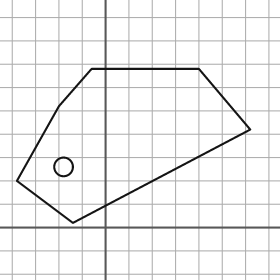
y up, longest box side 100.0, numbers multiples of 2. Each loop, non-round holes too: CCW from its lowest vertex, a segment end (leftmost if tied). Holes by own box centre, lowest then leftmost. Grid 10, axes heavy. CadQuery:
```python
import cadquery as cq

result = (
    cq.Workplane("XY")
    .moveTo(-14.0, 2.0)
    .lineTo(62.0, 42.0)
    .lineTo(40.0, 68.0)
    .lineTo(-6.0, 68.0)
    .lineTo(-20.0, 52.0)
    .lineTo(-38.0, 20.0)
    .close()
    .moveTo(-18.0, 26.0)
    .circle(4.0)
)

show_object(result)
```